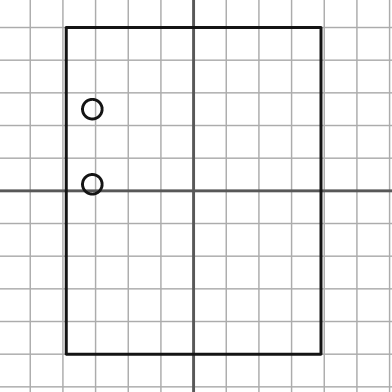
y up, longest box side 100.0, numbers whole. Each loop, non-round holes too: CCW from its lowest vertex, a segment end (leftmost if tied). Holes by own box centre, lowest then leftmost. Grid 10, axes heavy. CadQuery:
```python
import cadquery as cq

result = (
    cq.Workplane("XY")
    .moveTo(-39.0, -50.0)
    .lineTo(39.0, -50.0)
    .lineTo(39.0, 50.0)
    .lineTo(-39.0, 50.0)
    .close()
    .moveTo(-31.0, 2.0)
    .circle(3.0)
    .moveTo(-31.0, 25.0)
    .circle(3.0)
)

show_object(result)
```